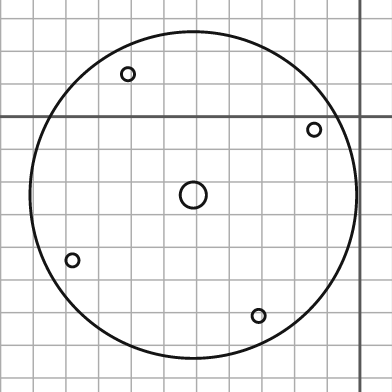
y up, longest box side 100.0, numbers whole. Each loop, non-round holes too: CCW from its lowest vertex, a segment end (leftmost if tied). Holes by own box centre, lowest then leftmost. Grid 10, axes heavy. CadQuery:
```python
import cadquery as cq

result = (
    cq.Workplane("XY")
    .moveTo(-51.0, -24.0)
    .circle(50.0)
    .moveTo(-31.0, -61.0)
    .circle(2.0)
    .moveTo(-88.0, -44.0)
    .circle(2.0)
    .moveTo(-51.0, -24.0)
    .circle(4.0)
    .moveTo(-14.0, -4.0)
    .circle(2.0)
    .moveTo(-71.0, 13.0)
    .circle(2.0)
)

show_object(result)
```